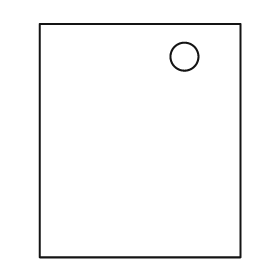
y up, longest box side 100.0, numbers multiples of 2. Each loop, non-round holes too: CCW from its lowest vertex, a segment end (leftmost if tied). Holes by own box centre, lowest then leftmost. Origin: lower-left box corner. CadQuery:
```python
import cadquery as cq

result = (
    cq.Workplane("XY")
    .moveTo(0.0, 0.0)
    .lineTo(86.0, 0.0)
    .lineTo(86.0, 100.0)
    .lineTo(0.0, 100.0)
    .close()
    .moveTo(62.0, 86.0)
    .circle(6.0)
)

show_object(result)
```